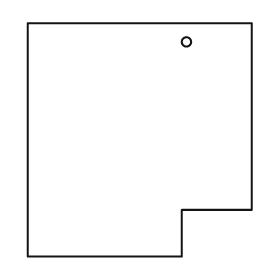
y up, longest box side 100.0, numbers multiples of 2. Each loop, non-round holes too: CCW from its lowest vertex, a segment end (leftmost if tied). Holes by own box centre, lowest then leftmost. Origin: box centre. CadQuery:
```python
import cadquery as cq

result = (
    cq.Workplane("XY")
    .moveTo(-48.0, -50.0)
    .lineTo(18.0, -50.0)
    .lineTo(18.0, -30.0)
    .lineTo(48.0, -30.0)
    .lineTo(48.0, 50.0)
    .lineTo(-48.0, 50.0)
    .close()
    .moveTo(20.0, 42.0)
    .circle(2.0)
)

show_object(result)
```